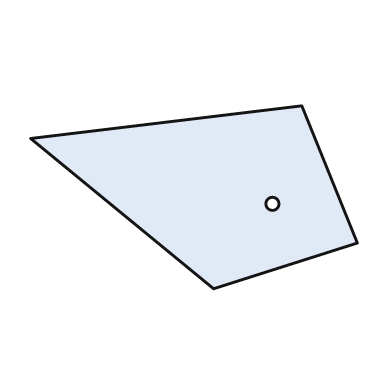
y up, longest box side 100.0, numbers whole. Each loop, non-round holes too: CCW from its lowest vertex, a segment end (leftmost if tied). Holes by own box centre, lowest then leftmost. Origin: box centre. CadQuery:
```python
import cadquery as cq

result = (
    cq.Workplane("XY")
    .moveTo(6.0, -28.0)
    .lineTo(50.0, -14.0)
    .lineTo(33.0, 28.0)
    .lineTo(-50.0, 18.0)
    .close()
    .moveTo(24.0, -2.0)
    .circle(2.0)
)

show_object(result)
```